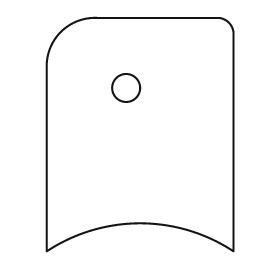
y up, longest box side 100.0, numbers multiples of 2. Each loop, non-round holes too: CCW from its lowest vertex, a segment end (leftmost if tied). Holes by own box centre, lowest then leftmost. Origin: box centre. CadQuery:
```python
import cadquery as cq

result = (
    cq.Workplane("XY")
    .moveTo(-40.0, -50.0)
    .threePointArc((0.0, -38.0), (40.0, -50.0))
    .lineTo(40.0, 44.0)
    .threePointArc((38.0, 48.0), (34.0, 50.0))
    .lineTo(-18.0, 50.0)
    .threePointArc((-34.0, 44.0), (-40.0, 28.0))
    .close()
    .moveTo(-6.0, 20.0)
    .circle(6.0)
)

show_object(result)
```